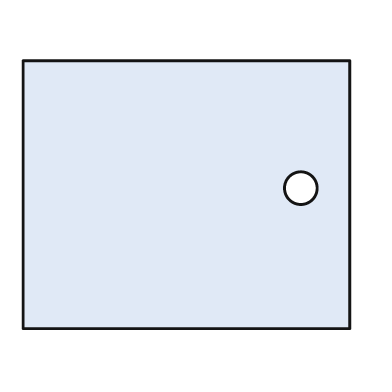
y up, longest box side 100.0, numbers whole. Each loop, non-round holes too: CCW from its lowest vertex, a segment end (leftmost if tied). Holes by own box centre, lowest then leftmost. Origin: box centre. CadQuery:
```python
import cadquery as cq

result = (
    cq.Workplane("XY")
    .moveTo(-50.0, -41.0)
    .lineTo(50.0, -41.0)
    .lineTo(50.0, 41.0)
    .lineTo(-50.0, 41.0)
    .close()
    .moveTo(35.0, 2.0)
    .circle(5.0)
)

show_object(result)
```